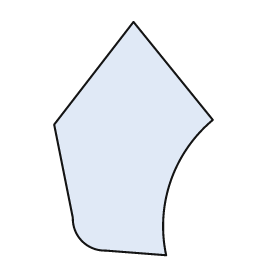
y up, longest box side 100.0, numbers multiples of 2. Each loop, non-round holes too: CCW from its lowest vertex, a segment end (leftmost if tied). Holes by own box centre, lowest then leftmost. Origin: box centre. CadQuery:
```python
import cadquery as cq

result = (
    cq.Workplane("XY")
    .moveTo(14.0, -50.0)
    .threePointArc((16.0, -18.0), (34.0, 8.0))
    .lineTo(0.0, 50.0)
    .lineTo(-34.0, 6.0)
    .lineTo(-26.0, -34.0)
    .threePointArc((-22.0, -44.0), (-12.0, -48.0))
    .close()
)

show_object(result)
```